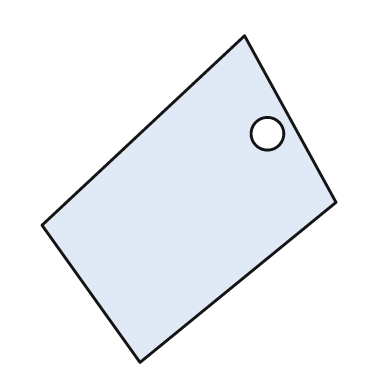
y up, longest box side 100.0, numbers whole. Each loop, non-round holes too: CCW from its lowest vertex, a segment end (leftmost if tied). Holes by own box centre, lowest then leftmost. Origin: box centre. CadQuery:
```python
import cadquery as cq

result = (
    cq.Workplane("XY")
    .moveTo(-15.0, -50.0)
    .lineTo(45.0, -1.0)
    .lineTo(17.0, 50.0)
    .lineTo(-45.0, -8.0)
    .close()
    .moveTo(24.0, 20.0)
    .circle(5.0)
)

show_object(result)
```